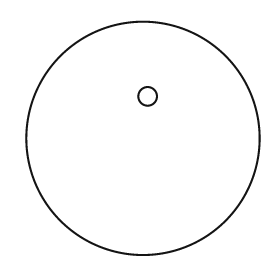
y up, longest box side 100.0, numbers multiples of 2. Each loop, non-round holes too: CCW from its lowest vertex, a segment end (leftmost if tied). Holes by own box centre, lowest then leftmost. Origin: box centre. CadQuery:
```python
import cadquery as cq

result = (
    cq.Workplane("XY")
    .moveTo(0.0, 0.0)
    .circle(50.0)
    .moveTo(2.0, 18.0)
    .circle(4.0)
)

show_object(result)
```